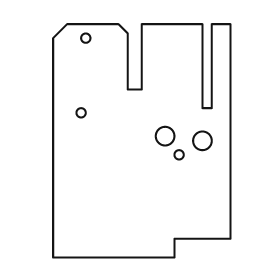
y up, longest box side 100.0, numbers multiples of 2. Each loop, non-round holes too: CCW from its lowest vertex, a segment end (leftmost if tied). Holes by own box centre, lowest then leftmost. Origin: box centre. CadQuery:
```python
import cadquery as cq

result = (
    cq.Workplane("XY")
    .moveTo(-38.0, -50.0)
    .lineTo(14.0, -50.0)
    .lineTo(14.0, -42.0)
    .lineTo(38.0, -42.0)
    .lineTo(38.0, 50.0)
    .lineTo(30.0, 50.0)
    .lineTo(30.0, 14.0)
    .lineTo(26.0, 14.0)
    .lineTo(26.0, 50.0)
    .lineTo(0.0, 50.0)
    .lineTo(0.0, 22.0)
    .lineTo(-6.0, 22.0)
    .lineTo(-6.0, 46.0)
    .lineTo(-10.0, 50.0)
    .lineTo(-32.0, 50.0)
    .lineTo(-38.0, 44.0)
    .close()
    .moveTo(16.0, -6.0)
    .circle(2.0)
    .moveTo(26.0, 0.0)
    .circle(4.0)
    .moveTo(10.0, 2.0)
    .circle(4.0)
    .moveTo(-26.0, 12.0)
    .circle(2.0)
    .moveTo(-24.0, 44.0)
    .circle(2.0)
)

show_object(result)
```